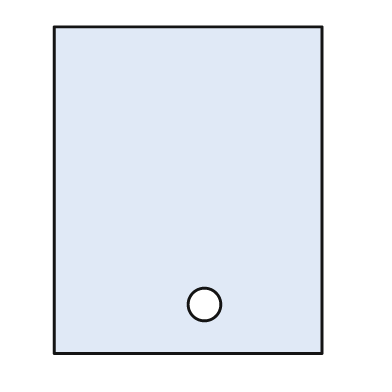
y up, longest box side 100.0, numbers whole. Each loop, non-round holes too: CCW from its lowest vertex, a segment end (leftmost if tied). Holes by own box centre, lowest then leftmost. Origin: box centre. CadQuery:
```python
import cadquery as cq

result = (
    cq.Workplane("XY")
    .moveTo(-41.0, -50.0)
    .lineTo(41.0, -50.0)
    .lineTo(41.0, 50.0)
    .lineTo(-41.0, 50.0)
    .close()
    .moveTo(5.0, -35.0)
    .circle(5.0)
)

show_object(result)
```